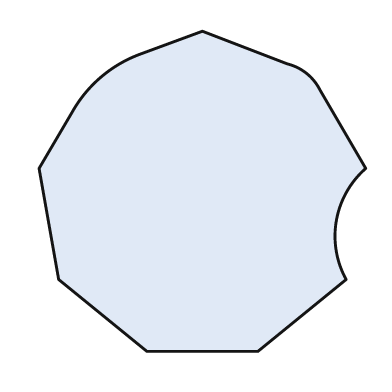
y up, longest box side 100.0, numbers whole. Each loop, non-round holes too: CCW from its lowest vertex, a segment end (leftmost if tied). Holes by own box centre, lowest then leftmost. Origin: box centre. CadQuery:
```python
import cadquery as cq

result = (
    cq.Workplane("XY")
    .moveTo(-17.0, -49.0)
    .lineTo(17.0, -49.0)
    .lineTo(44.0, -27.0)
    .threePointArc((41.0, -9.0), (50.0, 7.0))
    .lineTo(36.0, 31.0)
    .threePointArc((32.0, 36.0), (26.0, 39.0))
    .lineTo(0.0, 49.0)
    .lineTo(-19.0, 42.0)
    .threePointArc((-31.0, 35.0), (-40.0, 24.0))
    .lineTo(-50.0, 7.0)
    .lineTo(-44.0, -27.0)
    .close()
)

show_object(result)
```